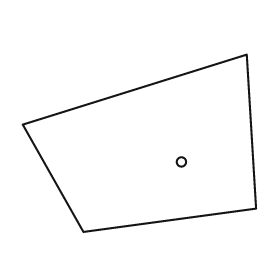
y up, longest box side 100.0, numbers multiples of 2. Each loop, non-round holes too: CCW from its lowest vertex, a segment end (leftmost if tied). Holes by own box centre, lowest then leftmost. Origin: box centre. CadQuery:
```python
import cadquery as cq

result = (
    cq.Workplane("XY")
    .moveTo(-24.0, -38.0)
    .lineTo(50.0, -28.0)
    .lineTo(46.0, 38.0)
    .lineTo(-50.0, 8.0)
    .close()
    .moveTo(18.0, -8.0)
    .circle(2.0)
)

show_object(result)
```